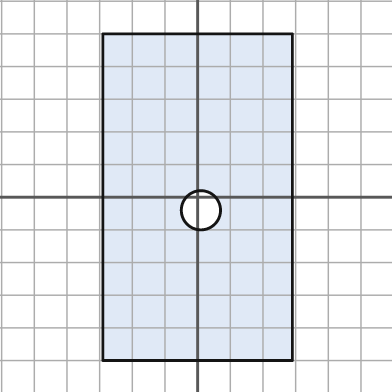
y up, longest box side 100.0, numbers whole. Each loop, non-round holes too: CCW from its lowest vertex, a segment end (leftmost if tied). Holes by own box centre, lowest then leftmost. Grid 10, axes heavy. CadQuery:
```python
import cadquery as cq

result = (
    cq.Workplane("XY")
    .moveTo(-29.0, -50.0)
    .lineTo(29.0, -50.0)
    .lineTo(29.0, 50.0)
    .lineTo(-29.0, 50.0)
    .close()
    .moveTo(1.0, -4.0)
    .circle(6.0)
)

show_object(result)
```